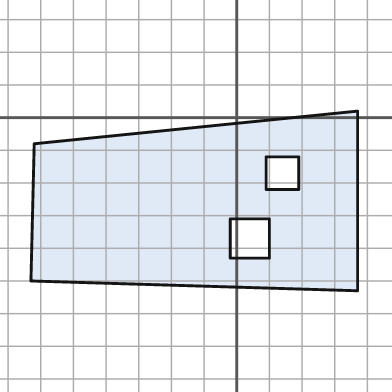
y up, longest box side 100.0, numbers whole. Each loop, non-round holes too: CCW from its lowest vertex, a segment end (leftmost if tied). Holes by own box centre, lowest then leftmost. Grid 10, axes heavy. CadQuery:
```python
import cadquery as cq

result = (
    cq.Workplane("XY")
    .moveTo(37.0, -53.0)
    .lineTo(37.0, 2.0)
    .lineTo(-62.0, -8.0)
    .lineTo(-63.0, -50.0)
    .close()
    .moveTo(-2.0, -43.0)
    .lineTo(10.0, -43.0)
    .lineTo(10.0, -31.0)
    .lineTo(-2.0, -31.0)
    .close()
    .moveTo(9.0, -22.0)
    .lineTo(19.0, -22.0)
    .lineTo(19.0, -12.0)
    .lineTo(9.0, -12.0)
    .close()
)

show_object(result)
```